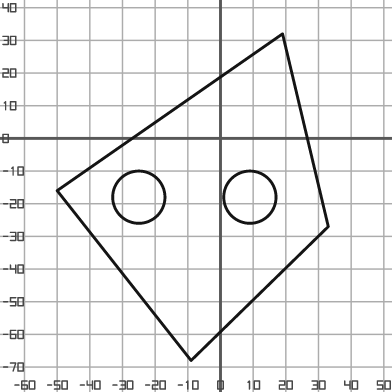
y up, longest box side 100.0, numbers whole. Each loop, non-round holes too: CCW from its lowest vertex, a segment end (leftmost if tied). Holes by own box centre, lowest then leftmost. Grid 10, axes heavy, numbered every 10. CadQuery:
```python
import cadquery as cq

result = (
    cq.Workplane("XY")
    .moveTo(-9.0, -68.0)
    .lineTo(33.0, -27.0)
    .lineTo(19.0, 32.0)
    .lineTo(-50.0, -16.0)
    .close()
    .moveTo(-25.0, -18.0)
    .circle(8.0)
    .moveTo(9.0, -18.0)
    .circle(8.0)
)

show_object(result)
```